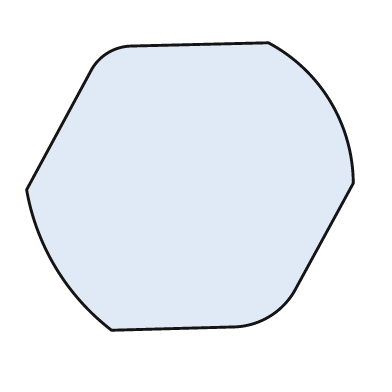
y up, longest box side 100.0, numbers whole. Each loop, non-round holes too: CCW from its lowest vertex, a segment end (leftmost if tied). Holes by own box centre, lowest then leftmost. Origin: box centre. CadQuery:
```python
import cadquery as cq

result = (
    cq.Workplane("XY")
    .moveTo(-24.0, -44.0)
    .lineTo(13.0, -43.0)
    .threePointArc((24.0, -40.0), (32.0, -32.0))
    .lineTo(50.0, 1.0)
    .threePointArc((43.0, 26.0), (24.0, 44.0))
    .lineTo(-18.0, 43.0)
    .threePointArc((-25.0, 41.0), (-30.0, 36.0))
    .lineTo(-50.0, -1.0)
    .threePointArc((-41.0, -25.0), (-24.0, -44.0))
    .close()
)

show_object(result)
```